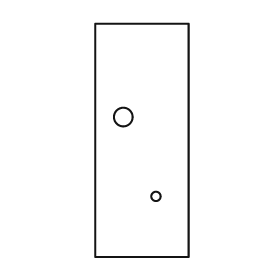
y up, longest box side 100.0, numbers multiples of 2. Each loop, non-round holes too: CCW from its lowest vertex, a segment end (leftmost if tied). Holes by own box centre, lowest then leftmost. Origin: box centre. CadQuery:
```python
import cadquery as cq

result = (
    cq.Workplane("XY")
    .moveTo(-20.0, -50.0)
    .lineTo(20.0, -50.0)
    .lineTo(20.0, 50.0)
    .lineTo(-20.0, 50.0)
    .close()
    .moveTo(6.0, -24.0)
    .circle(2.0)
    .moveTo(-8.0, 10.0)
    .circle(4.0)
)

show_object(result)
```